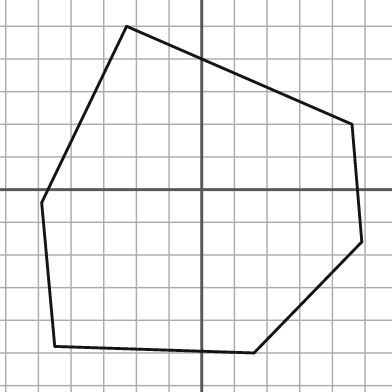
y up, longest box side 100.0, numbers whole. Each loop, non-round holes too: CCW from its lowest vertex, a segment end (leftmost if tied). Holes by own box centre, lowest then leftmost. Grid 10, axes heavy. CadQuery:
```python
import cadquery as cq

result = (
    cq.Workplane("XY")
    .moveTo(16.0, -50.0)
    .lineTo(49.0, -16.0)
    .lineTo(46.0, 20.0)
    .lineTo(-23.0, 50.0)
    .lineTo(-49.0, -4.0)
    .lineTo(-45.0, -48.0)
    .close()
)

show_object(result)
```